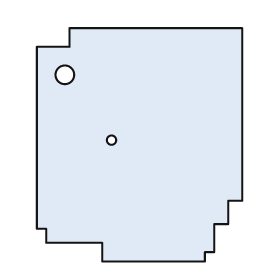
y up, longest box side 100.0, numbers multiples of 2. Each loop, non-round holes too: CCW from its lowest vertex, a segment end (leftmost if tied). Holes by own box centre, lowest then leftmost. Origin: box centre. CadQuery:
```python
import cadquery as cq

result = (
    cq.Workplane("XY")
    .moveTo(-16.0, -50.0)
    .lineTo(28.0, -50.0)
    .lineTo(28.0, -46.0)
    .lineTo(32.0, -46.0)
    .lineTo(32.0, -34.0)
    .lineTo(38.0, -34.0)
    .lineTo(38.0, -24.0)
    .lineTo(44.0, -24.0)
    .lineTo(44.0, 50.0)
    .lineTo(-30.0, 50.0)
    .lineTo(-30.0, 42.0)
    .lineTo(-44.0, 42.0)
    .lineTo(-44.0, -36.0)
    .lineTo(-40.0, -36.0)
    .lineTo(-40.0, -42.0)
    .lineTo(-16.0, -42.0)
    .close()
    .moveTo(-12.0, 2.0)
    .circle(2.0)
    .moveTo(-32.0, 30.0)
    .circle(4.0)
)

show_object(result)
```